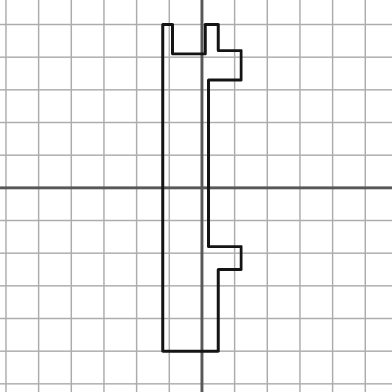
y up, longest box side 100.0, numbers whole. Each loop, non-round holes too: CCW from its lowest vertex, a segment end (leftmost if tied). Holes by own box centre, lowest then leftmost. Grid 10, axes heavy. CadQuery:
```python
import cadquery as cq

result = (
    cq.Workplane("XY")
    .moveTo(-12.0, -50.0)
    .lineTo(5.0, -50.0)
    .lineTo(5.0, -25.0)
    .lineTo(12.0, -25.0)
    .lineTo(12.0, -18.0)
    .lineTo(2.0, -18.0)
    .lineTo(2.0, 33.0)
    .lineTo(12.0, 33.0)
    .lineTo(12.0, 42.0)
    .lineTo(5.0, 42.0)
    .lineTo(5.0, 50.0)
    .lineTo(1.0, 50.0)
    .lineTo(1.0, 41.0)
    .lineTo(-9.0, 41.0)
    .lineTo(-9.0, 50.0)
    .lineTo(-12.0, 50.0)
    .close()
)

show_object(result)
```